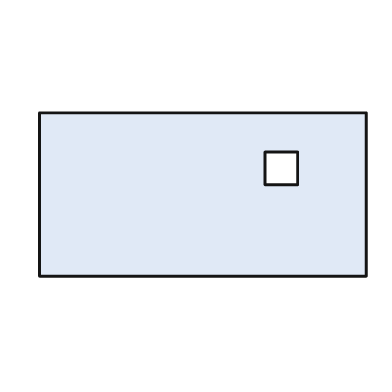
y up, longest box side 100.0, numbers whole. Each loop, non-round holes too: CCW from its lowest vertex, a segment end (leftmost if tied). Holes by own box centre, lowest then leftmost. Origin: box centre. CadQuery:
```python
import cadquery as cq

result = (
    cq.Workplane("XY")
    .moveTo(-50.0, -25.0)
    .lineTo(50.0, -25.0)
    .lineTo(50.0, 25.0)
    .lineTo(-50.0, 25.0)
    .close()
    .moveTo(19.0, 3.0)
    .lineTo(29.0, 3.0)
    .lineTo(29.0, 13.0)
    .lineTo(19.0, 13.0)
    .close()
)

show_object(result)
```